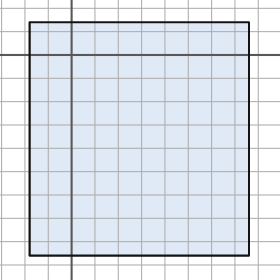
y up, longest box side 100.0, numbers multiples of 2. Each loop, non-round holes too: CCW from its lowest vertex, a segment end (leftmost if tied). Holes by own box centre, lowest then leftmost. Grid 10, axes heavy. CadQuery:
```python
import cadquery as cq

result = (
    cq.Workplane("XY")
    .moveTo(-18.0, -86.0)
    .lineTo(76.0, -86.0)
    .lineTo(76.0, 14.0)
    .lineTo(-18.0, 14.0)
    .close()
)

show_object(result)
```